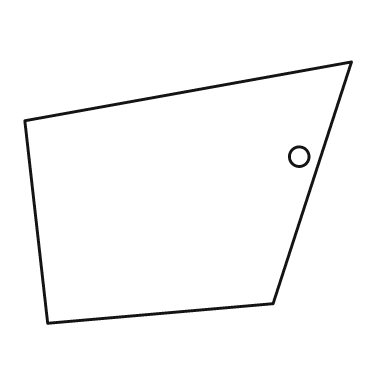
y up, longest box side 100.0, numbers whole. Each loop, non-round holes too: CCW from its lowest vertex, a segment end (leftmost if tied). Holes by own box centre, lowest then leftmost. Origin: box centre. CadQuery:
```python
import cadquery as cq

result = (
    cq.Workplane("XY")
    .moveTo(-43.0, -40.0)
    .lineTo(26.0, -34.0)
    .lineTo(50.0, 40.0)
    .lineTo(-50.0, 22.0)
    .close()
    .moveTo(34.0, 11.0)
    .circle(3.0)
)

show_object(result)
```